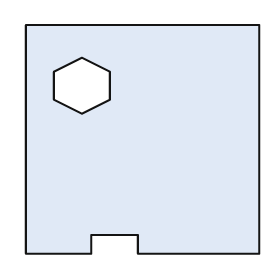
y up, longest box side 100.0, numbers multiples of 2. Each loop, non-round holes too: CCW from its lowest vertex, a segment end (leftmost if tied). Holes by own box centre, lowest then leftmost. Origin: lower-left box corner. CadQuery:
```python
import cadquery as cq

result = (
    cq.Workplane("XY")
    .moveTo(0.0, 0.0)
    .lineTo(28.0, 0.0)
    .lineTo(28.0, 8.0)
    .lineTo(48.0, 8.0)
    .lineTo(48.0, 0.0)
    .lineTo(100.0, 0.0)
    .lineTo(100.0, 98.0)
    .lineTo(0.0, 98.0)
    .close()
    .moveTo(24.0, 60.0)
    .lineTo(36.0, 66.0)
    .lineTo(36.0, 78.0)
    .lineTo(24.0, 84.0)
    .lineTo(12.0, 78.0)
    .lineTo(12.0, 66.0)
    .close()
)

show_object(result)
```